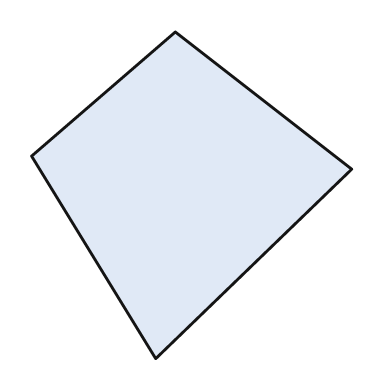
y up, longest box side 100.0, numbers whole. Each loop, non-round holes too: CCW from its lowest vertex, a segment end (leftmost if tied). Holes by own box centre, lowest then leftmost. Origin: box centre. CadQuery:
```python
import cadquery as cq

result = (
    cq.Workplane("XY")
    .moveTo(-11.0, -50.0)
    .lineTo(49.0, 8.0)
    .lineTo(-5.0, 50.0)
    .lineTo(-49.0, 12.0)
    .close()
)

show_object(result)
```